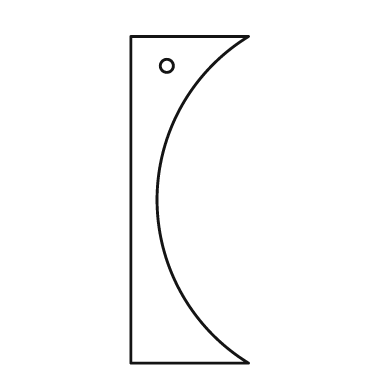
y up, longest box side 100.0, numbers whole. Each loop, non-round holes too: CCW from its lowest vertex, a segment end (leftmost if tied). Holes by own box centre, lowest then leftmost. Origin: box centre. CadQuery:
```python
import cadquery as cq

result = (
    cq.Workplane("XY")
    .moveTo(-18.0, -50.0)
    .lineTo(18.0, -50.0)
    .threePointArc((-10.0, 0.0), (18.0, 50.0))
    .lineTo(-18.0, 50.0)
    .close()
    .moveTo(-7.0, 41.0)
    .circle(2.0)
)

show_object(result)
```